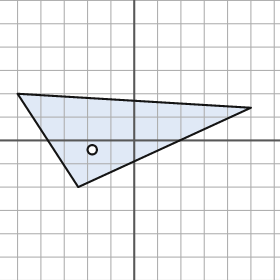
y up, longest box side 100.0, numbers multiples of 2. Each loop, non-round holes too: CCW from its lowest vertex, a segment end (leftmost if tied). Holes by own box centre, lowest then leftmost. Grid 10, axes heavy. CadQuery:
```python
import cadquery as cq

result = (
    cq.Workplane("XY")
    .moveTo(-24.0, -20.0)
    .lineTo(50.0, 14.0)
    .lineTo(-50.0, 20.0)
    .close()
    .moveTo(-18.0, -4.0)
    .circle(2.0)
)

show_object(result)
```